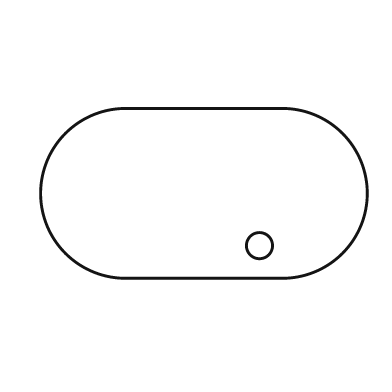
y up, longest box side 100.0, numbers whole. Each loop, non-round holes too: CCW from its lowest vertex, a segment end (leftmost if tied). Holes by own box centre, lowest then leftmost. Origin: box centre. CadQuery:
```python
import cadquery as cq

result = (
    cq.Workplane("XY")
    .moveTo(-24.0, -26.0)
    .lineTo(24.0, -26.0)
    .threePointArc((50.0, 0.0), (24.0, 26.0))
    .lineTo(-24.0, 26.0)
    .threePointArc((-50.0, 0.0), (-24.0, -26.0))
    .close()
    .moveTo(17.0, -16.0)
    .circle(4.0)
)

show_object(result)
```